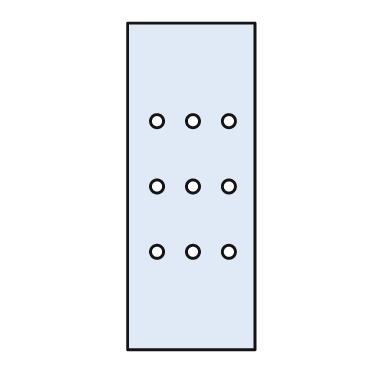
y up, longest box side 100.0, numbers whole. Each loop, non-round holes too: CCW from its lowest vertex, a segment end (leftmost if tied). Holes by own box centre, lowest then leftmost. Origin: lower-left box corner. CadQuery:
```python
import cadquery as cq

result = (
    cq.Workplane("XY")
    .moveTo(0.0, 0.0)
    .lineTo(39.0, 0.0)
    .lineTo(39.0, 100.0)
    .lineTo(0.0, 100.0)
    .close()
    .moveTo(9.0, 30.0)
    .circle(2.0)
    .moveTo(20.0, 30.0)
    .circle(2.0)
    .moveTo(31.0, 30.0)
    .circle(2.0)
    .moveTo(9.0, 50.0)
    .circle(2.0)
    .moveTo(20.0, 50.0)
    .circle(2.0)
    .moveTo(31.0, 50.0)
    .circle(2.0)
    .moveTo(9.0, 70.0)
    .circle(2.0)
    .moveTo(20.0, 70.0)
    .circle(2.0)
    .moveTo(31.0, 70.0)
    .circle(2.0)
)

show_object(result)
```